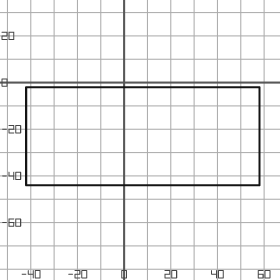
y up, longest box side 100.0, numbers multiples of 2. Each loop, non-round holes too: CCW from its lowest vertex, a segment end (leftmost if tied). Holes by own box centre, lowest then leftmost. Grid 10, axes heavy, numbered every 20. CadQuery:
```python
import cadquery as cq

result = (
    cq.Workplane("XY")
    .moveTo(-42.0, -44.0)
    .lineTo(58.0, -44.0)
    .lineTo(58.0, -2.0)
    .lineTo(-42.0, -2.0)
    .close()
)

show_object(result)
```